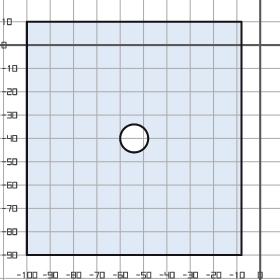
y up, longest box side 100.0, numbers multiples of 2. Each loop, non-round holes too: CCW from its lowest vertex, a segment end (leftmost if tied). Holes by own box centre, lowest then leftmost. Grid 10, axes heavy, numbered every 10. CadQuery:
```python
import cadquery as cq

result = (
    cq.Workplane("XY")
    .moveTo(-100.0, -90.0)
    .lineTo(-8.0, -90.0)
    .lineTo(-8.0, 10.0)
    .lineTo(-100.0, 10.0)
    .close()
    .moveTo(-54.0, -40.0)
    .circle(6.0)
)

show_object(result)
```